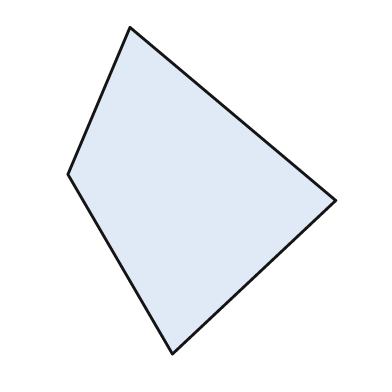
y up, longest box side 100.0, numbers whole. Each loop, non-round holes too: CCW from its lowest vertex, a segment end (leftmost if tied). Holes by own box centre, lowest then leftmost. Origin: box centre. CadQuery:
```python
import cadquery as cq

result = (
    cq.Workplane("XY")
    .moveTo(-9.0, -50.0)
    .lineTo(41.0, -3.0)
    .lineTo(-22.0, 50.0)
    .lineTo(-41.0, 5.0)
    .close()
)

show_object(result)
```